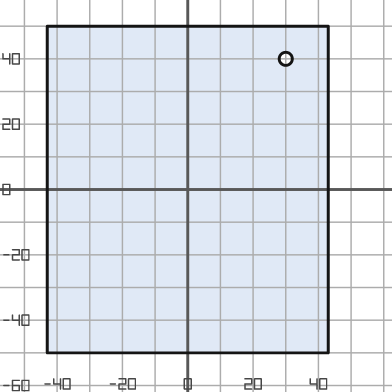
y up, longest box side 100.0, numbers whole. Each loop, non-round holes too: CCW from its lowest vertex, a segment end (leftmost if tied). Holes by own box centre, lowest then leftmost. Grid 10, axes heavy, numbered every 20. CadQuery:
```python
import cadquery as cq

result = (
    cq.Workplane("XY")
    .moveTo(-43.0, -50.0)
    .lineTo(43.0, -50.0)
    .lineTo(43.0, 50.0)
    .lineTo(-43.0, 50.0)
    .close()
    .moveTo(30.0, 40.0)
    .circle(2.0)
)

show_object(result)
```